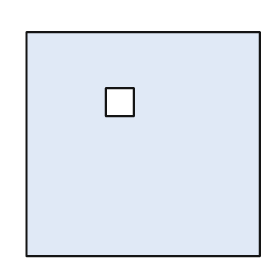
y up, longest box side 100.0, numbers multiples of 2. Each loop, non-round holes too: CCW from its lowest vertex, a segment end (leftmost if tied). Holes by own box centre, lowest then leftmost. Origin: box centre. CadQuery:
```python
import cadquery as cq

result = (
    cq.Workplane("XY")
    .moveTo(-50.0, -48.0)
    .lineTo(50.0, -48.0)
    .lineTo(50.0, 48.0)
    .lineTo(-50.0, 48.0)
    .close()
    .moveTo(-16.0, 12.0)
    .lineTo(-4.0, 12.0)
    .lineTo(-4.0, 24.0)
    .lineTo(-16.0, 24.0)
    .close()
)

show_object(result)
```